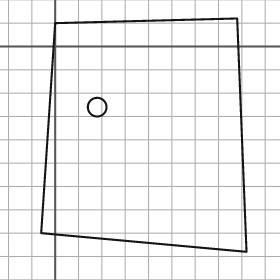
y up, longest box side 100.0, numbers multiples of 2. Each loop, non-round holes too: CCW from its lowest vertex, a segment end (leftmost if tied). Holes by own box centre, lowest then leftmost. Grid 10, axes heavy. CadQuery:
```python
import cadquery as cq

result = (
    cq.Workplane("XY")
    .moveTo(82.0, -88.0)
    .lineTo(78.0, 12.0)
    .lineTo(0.0, 10.0)
    .lineTo(-6.0, -80.0)
    .close()
    .moveTo(18.0, -26.0)
    .circle(4.0)
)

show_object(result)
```